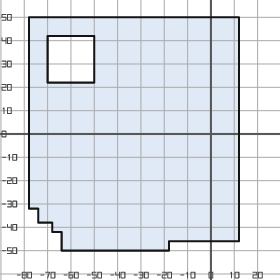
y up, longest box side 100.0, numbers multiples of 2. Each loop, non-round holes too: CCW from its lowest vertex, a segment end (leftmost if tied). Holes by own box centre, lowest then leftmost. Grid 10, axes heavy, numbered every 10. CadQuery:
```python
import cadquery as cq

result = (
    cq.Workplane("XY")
    .moveTo(-64.0, -50.0)
    .lineTo(-18.0, -50.0)
    .lineTo(-18.0, -46.0)
    .lineTo(12.0, -46.0)
    .lineTo(12.0, 50.0)
    .lineTo(-78.0, 50.0)
    .lineTo(-78.0, -32.0)
    .lineTo(-74.0, -32.0)
    .lineTo(-74.0, -38.0)
    .lineTo(-68.0, -38.0)
    .lineTo(-68.0, -42.0)
    .lineTo(-64.0, -42.0)
    .close()
    .moveTo(-70.0, 22.0)
    .lineTo(-50.0, 22.0)
    .lineTo(-50.0, 42.0)
    .lineTo(-70.0, 42.0)
    .close()
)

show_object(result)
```